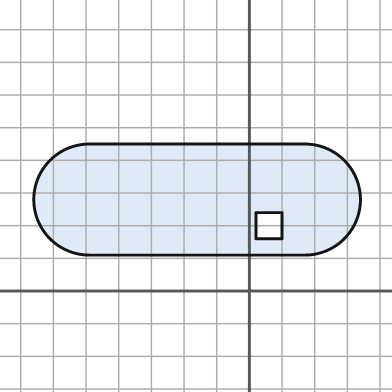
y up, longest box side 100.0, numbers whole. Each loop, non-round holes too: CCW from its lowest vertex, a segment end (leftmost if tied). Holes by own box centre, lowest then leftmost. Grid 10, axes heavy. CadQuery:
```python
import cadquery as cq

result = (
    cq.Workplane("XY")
    .moveTo(-49.0, 11.0)
    .lineTo(17.0, 11.0)
    .threePointArc((34.0, 28.0), (17.0, 45.0))
    .lineTo(-49.0, 45.0)
    .threePointArc((-66.0, 28.0), (-49.0, 11.0))
    .close()
    .moveTo(2.0, 16.0)
    .lineTo(10.0, 16.0)
    .lineTo(10.0, 24.0)
    .lineTo(2.0, 24.0)
    .close()
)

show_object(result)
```